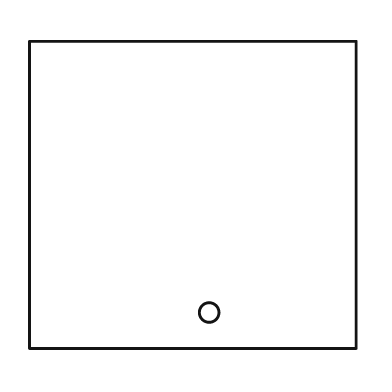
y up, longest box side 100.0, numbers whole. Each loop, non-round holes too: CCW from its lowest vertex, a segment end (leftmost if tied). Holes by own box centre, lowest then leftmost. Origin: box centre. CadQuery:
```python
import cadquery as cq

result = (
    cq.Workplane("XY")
    .moveTo(-50.0, -47.0)
    .lineTo(50.0, -47.0)
    .lineTo(50.0, 47.0)
    .lineTo(-50.0, 47.0)
    .close()
    .moveTo(5.0, -36.0)
    .circle(3.0)
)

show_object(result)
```